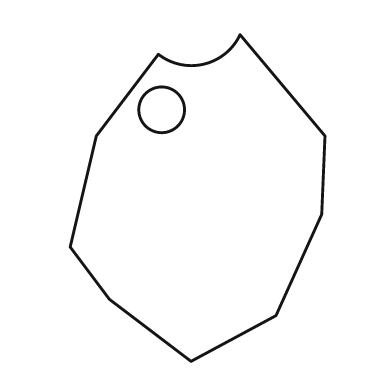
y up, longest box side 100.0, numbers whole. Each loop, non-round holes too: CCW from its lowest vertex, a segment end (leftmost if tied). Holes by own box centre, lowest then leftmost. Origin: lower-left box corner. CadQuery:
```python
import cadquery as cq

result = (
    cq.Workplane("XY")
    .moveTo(37.0, 0.0)
    .lineTo(63.0, 14.0)
    .lineTo(77.0, 45.0)
    .lineTo(78.0, 69.0)
    .lineTo(52.0, 100.0)
    .threePointArc((41.0, 91.0), (27.0, 94.0))
    .lineTo(8.0, 69.0)
    .lineTo(0.0, 35.0)
    .lineTo(12.0, 19.0)
    .close()
    .moveTo(28.0, 77.0)
    .circle(7.0)
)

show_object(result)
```